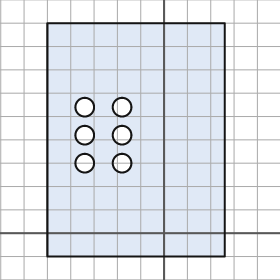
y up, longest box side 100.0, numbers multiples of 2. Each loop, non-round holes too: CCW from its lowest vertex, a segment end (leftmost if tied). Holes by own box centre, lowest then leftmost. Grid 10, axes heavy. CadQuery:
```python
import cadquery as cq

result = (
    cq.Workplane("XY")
    .moveTo(-50.0, -10.0)
    .lineTo(26.0, -10.0)
    .lineTo(26.0, 90.0)
    .lineTo(-50.0, 90.0)
    .close()
    .moveTo(-34.0, 30.0)
    .circle(4.0)
    .moveTo(-18.0, 30.0)
    .circle(4.0)
    .moveTo(-34.0, 42.0)
    .circle(4.0)
    .moveTo(-18.0, 42.0)
    .circle(4.0)
    .moveTo(-34.0, 54.0)
    .circle(4.0)
    .moveTo(-18.0, 54.0)
    .circle(4.0)
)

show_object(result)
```